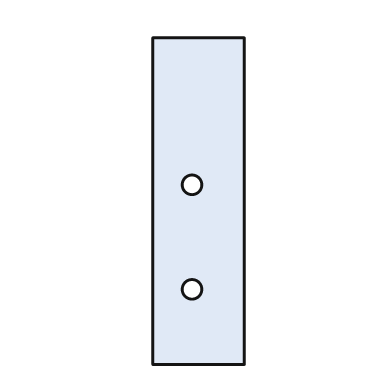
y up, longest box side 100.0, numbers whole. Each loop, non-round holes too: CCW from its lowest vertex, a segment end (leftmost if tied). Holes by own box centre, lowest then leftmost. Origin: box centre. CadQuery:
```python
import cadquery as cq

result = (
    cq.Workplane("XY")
    .moveTo(-14.0, -50.0)
    .lineTo(14.0, -50.0)
    .lineTo(14.0, 50.0)
    .lineTo(-14.0, 50.0)
    .close()
    .moveTo(-2.0, -27.0)
    .circle(3.0)
    .moveTo(-2.0, 5.0)
    .circle(3.0)
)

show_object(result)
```